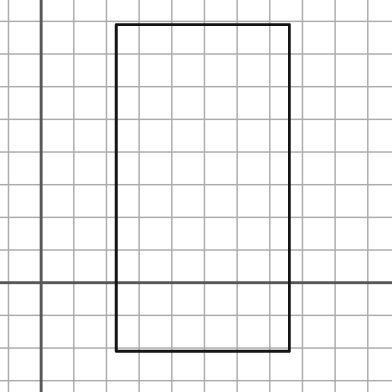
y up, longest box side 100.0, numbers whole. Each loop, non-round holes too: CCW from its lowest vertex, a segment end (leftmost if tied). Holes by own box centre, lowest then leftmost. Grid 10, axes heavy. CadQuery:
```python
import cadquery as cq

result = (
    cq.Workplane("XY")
    .moveTo(23.0, -21.0)
    .lineTo(76.0, -21.0)
    .lineTo(76.0, 79.0)
    .lineTo(23.0, 79.0)
    .close()
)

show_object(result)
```